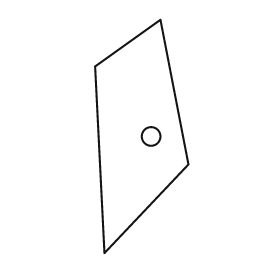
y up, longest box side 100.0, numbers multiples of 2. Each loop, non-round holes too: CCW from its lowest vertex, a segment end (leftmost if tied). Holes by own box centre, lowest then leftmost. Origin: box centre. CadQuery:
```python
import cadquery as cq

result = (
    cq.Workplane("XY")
    .moveTo(-16.0, -50.0)
    .lineTo(20.0, -12.0)
    .lineTo(8.0, 50.0)
    .lineTo(-20.0, 30.0)
    .close()
    .moveTo(4.0, 0.0)
    .circle(4.0)
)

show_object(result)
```